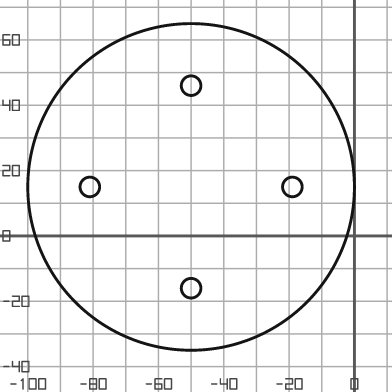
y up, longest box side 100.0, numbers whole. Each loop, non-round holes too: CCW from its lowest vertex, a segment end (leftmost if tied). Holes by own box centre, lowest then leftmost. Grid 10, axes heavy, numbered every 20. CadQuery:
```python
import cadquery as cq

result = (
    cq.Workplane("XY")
    .moveTo(-50.0, 15.0)
    .circle(50.0)
    .moveTo(-50.0, -16.0)
    .circle(3.0)
    .moveTo(-81.0, 15.0)
    .circle(3.0)
    .moveTo(-19.0, 15.0)
    .circle(3.0)
    .moveTo(-50.0, 46.0)
    .circle(3.0)
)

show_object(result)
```